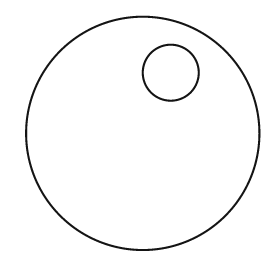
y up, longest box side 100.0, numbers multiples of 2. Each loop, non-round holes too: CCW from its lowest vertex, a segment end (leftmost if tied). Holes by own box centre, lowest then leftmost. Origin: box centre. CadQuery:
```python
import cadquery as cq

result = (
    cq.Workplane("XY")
    .moveTo(0.0, 0.0)
    .circle(50.0)
    .moveTo(12.0, 26.0)
    .circle(12.0)
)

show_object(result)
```